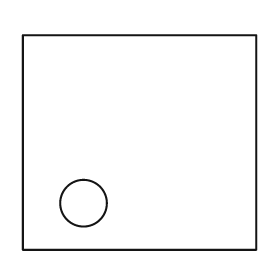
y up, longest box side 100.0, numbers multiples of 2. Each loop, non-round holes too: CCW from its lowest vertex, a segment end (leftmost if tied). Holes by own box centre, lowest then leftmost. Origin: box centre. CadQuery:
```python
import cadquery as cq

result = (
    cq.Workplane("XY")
    .moveTo(-50.0, -46.0)
    .lineTo(50.0, -46.0)
    .lineTo(50.0, 46.0)
    .lineTo(-50.0, 46.0)
    .close()
    .moveTo(-24.0, -26.0)
    .circle(10.0)
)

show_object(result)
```